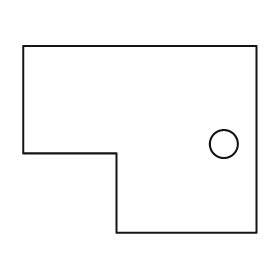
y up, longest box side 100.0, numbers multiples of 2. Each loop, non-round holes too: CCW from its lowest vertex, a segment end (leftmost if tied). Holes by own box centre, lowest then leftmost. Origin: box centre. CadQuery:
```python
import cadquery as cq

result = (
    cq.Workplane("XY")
    .moveTo(-10.0, -40.0)
    .lineTo(50.0, -40.0)
    .lineTo(50.0, 40.0)
    .lineTo(-50.0, 40.0)
    .lineTo(-50.0, -6.0)
    .lineTo(-10.0, -6.0)
    .close()
    .moveTo(36.0, -2.0)
    .circle(6.0)
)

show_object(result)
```